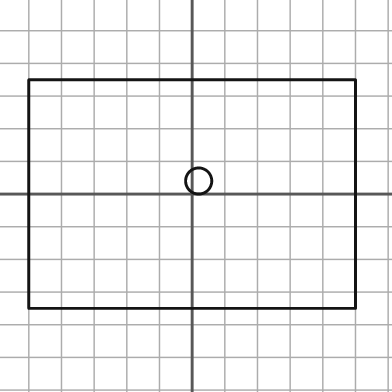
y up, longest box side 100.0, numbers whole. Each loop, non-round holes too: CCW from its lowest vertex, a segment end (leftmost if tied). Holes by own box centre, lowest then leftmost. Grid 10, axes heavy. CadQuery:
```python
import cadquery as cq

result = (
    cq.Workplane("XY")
    .moveTo(-50.0, -35.0)
    .lineTo(50.0, -35.0)
    .lineTo(50.0, 35.0)
    .lineTo(-50.0, 35.0)
    .close()
    .moveTo(2.0, 4.0)
    .circle(4.0)
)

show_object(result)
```